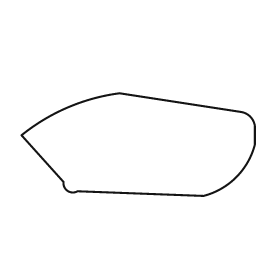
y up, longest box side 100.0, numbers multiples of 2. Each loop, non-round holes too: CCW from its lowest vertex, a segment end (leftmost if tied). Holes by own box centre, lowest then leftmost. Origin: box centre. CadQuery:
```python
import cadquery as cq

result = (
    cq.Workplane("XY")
    .moveTo(28.0, -22.0)
    .threePointArc((42.0, -14.0), (50.0, 0.0))
    .lineTo(50.0, 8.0)
    .threePointArc((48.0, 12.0), (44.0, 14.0))
    .lineTo(-8.0, 22.0)
    .threePointArc((-30.0, 16.0), (-50.0, 4.0))
    .lineTo(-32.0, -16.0)
    .threePointArc((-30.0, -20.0), (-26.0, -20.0))
    .close()
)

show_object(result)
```